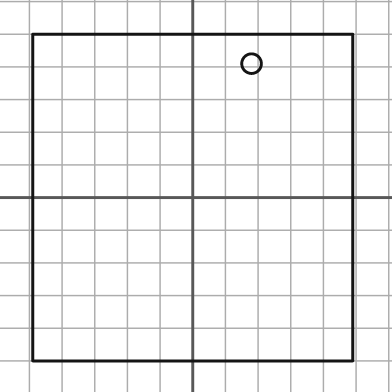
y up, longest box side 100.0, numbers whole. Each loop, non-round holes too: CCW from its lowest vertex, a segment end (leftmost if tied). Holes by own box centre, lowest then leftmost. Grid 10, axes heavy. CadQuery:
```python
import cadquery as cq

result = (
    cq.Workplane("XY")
    .moveTo(-49.0, -50.0)
    .lineTo(49.0, -50.0)
    .lineTo(49.0, 50.0)
    .lineTo(-49.0, 50.0)
    .close()
    .moveTo(18.0, 41.0)
    .circle(3.0)
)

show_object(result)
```